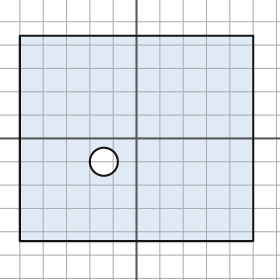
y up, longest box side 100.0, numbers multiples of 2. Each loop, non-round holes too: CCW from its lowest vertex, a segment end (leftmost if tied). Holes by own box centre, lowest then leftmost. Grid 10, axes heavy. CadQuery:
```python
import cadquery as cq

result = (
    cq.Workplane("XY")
    .moveTo(-50.0, -44.0)
    .lineTo(50.0, -44.0)
    .lineTo(50.0, 44.0)
    .lineTo(-50.0, 44.0)
    .close()
    .moveTo(-14.0, -10.0)
    .circle(6.0)
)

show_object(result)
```